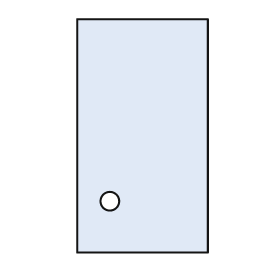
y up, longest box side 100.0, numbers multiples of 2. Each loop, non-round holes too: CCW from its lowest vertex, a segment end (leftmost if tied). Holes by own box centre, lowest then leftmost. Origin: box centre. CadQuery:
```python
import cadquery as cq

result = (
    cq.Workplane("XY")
    .moveTo(-28.0, -50.0)
    .lineTo(28.0, -50.0)
    .lineTo(28.0, 50.0)
    .lineTo(-28.0, 50.0)
    .close()
    .moveTo(-14.0, -28.0)
    .circle(4.0)
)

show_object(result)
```